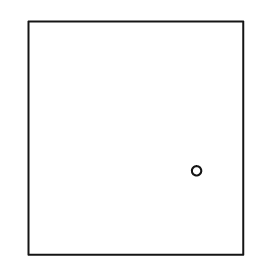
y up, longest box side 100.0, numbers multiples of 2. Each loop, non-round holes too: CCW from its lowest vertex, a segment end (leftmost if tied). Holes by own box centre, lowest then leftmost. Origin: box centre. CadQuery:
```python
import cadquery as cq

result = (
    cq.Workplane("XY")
    .moveTo(-46.0, -50.0)
    .lineTo(46.0, -50.0)
    .lineTo(46.0, 50.0)
    .lineTo(-46.0, 50.0)
    .close()
    .moveTo(26.0, -14.0)
    .circle(2.0)
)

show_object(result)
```